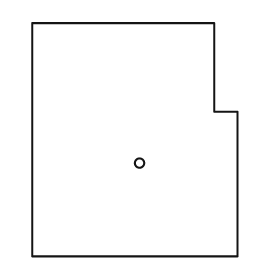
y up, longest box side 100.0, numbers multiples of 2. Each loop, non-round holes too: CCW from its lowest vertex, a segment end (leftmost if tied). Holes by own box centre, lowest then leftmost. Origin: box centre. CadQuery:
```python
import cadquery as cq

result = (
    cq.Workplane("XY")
    .moveTo(-44.0, -50.0)
    .lineTo(44.0, -50.0)
    .lineTo(44.0, 12.0)
    .lineTo(34.0, 12.0)
    .lineTo(34.0, 50.0)
    .lineTo(-44.0, 50.0)
    .close()
    .moveTo(2.0, -10.0)
    .circle(2.0)
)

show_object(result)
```